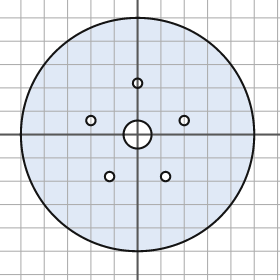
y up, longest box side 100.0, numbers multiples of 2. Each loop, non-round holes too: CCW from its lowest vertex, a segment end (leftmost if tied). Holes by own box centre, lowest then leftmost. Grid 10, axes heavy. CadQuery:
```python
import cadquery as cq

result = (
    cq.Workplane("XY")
    .moveTo(0.0, 0.0)
    .circle(50.0)
    .moveTo(-12.0, -18.0)
    .circle(2.0)
    .moveTo(12.0, -18.0)
    .circle(2.0)
    .moveTo(0.0, 0.0)
    .circle(6.0)
    .moveTo(-20.0, 6.0)
    .circle(2.0)
    .moveTo(20.0, 6.0)
    .circle(2.0)
    .moveTo(0.0, 22.0)
    .circle(2.0)
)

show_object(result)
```